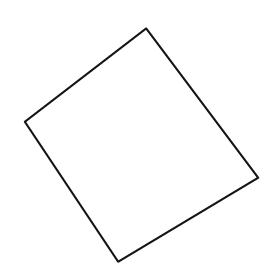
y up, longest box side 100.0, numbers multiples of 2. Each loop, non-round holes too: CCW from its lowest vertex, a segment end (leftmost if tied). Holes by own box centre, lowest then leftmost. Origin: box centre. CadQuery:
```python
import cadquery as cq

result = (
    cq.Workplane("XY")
    .moveTo(-10.0, -50.0)
    .lineTo(50.0, -14.0)
    .lineTo(2.0, 50.0)
    .lineTo(-50.0, 10.0)
    .close()
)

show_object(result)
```